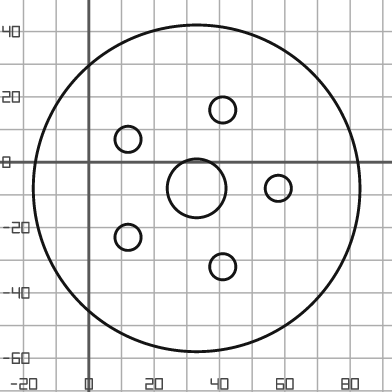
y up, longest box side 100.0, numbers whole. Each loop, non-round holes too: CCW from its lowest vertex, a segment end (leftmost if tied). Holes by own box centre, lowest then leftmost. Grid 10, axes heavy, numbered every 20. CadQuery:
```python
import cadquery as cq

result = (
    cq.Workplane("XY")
    .moveTo(33.0, -8.0)
    .circle(50.0)
    .moveTo(41.0, -32.0)
    .circle(4.0)
    .moveTo(12.0, -23.0)
    .circle(4.0)
    .moveTo(33.0, -8.0)
    .circle(9.0)
    .moveTo(58.0, -8.0)
    .circle(4.0)
    .moveTo(12.0, 7.0)
    .circle(4.0)
    .moveTo(41.0, 16.0)
    .circle(4.0)
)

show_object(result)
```